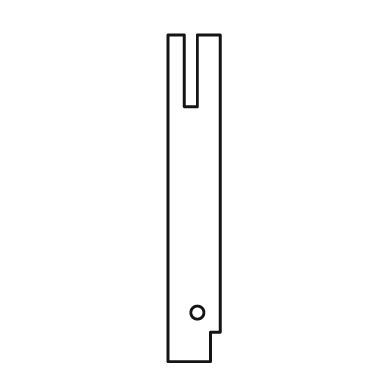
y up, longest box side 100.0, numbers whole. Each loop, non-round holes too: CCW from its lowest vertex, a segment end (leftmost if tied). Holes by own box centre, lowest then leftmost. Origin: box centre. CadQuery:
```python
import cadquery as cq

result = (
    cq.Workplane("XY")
    .moveTo(-8.0, -50.0)
    .lineTo(5.0, -50.0)
    .lineTo(5.0, -41.0)
    .lineTo(8.0, -41.0)
    .lineTo(8.0, 50.0)
    .lineTo(1.0, 50.0)
    .lineTo(1.0, 28.0)
    .lineTo(-3.0, 28.0)
    .lineTo(-3.0, 50.0)
    .lineTo(-8.0, 50.0)
    .close()
    .moveTo(1.0, -35.0)
    .circle(2.0)
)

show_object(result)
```